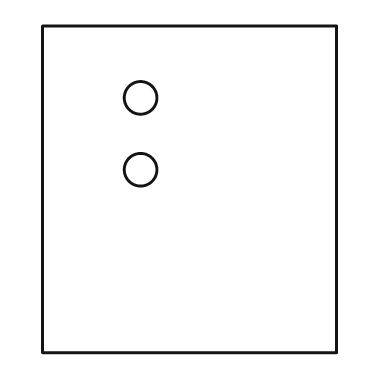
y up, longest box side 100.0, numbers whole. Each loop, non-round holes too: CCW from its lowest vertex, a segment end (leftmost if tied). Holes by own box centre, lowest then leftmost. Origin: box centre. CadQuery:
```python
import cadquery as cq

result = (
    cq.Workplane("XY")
    .moveTo(-45.0, -50.0)
    .lineTo(45.0, -50.0)
    .lineTo(45.0, 50.0)
    .lineTo(-45.0, 50.0)
    .close()
    .moveTo(-15.0, 6.0)
    .circle(5.0)
    .moveTo(-15.0, 28.0)
    .circle(5.0)
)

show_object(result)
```